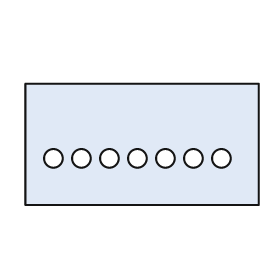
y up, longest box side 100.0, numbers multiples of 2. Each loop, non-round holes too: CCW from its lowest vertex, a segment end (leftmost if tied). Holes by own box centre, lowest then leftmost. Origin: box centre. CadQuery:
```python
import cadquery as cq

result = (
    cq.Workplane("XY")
    .moveTo(-50.0, -26.0)
    .lineTo(50.0, -26.0)
    .lineTo(50.0, 26.0)
    .lineTo(-50.0, 26.0)
    .close()
    .moveTo(-38.0, -6.0)
    .circle(4.0)
    .moveTo(-26.0, -6.0)
    .circle(4.0)
    .moveTo(-14.0, -6.0)
    .circle(4.0)
    .moveTo(-2.0, -6.0)
    .circle(4.0)
    .moveTo(10.0, -6.0)
    .circle(4.0)
    .moveTo(22.0, -6.0)
    .circle(4.0)
    .moveTo(34.0, -6.0)
    .circle(4.0)
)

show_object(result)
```